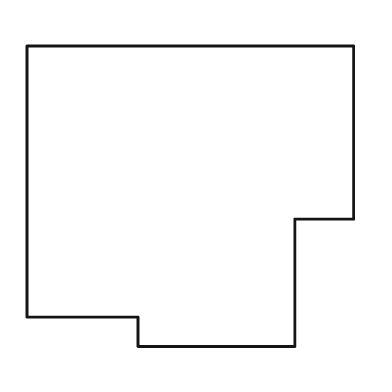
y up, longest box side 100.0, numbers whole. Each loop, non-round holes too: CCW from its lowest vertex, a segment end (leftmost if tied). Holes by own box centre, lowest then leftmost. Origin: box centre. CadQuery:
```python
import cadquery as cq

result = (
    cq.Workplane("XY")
    .moveTo(-16.0, -46.0)
    .lineTo(32.0, -46.0)
    .lineTo(32.0, -7.0)
    .lineTo(50.0, -7.0)
    .lineTo(50.0, 46.0)
    .lineTo(-50.0, 46.0)
    .lineTo(-50.0, -37.0)
    .lineTo(-16.0, -37.0)
    .close()
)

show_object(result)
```